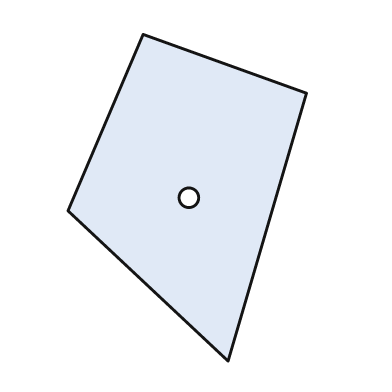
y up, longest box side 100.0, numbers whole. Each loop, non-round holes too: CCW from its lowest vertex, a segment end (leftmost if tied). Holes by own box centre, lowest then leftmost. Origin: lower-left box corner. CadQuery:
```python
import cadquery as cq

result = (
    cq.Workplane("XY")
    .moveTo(49.0, 0.0)
    .lineTo(73.0, 82.0)
    .lineTo(23.0, 100.0)
    .lineTo(0.0, 46.0)
    .close()
    .moveTo(37.0, 50.0)
    .circle(3.0)
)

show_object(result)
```